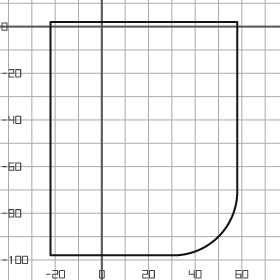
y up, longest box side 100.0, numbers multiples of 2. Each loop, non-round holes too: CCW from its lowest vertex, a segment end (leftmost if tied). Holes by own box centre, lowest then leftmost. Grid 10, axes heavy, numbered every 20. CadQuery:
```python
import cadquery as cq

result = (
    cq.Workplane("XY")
    .moveTo(-22.0, -98.0)
    .lineTo(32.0, -98.0)
    .threePointArc((50.0, -90.0), (58.0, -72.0))
    .lineTo(58.0, 2.0)
    .lineTo(-22.0, 2.0)
    .close()
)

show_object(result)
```